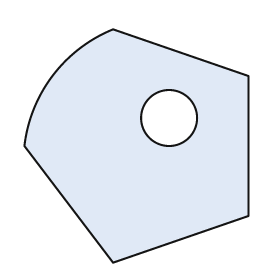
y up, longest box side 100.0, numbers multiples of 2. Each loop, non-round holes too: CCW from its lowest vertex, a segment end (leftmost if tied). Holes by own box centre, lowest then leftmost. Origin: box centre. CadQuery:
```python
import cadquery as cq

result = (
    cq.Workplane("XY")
    .moveTo(-10.0, -50.0)
    .lineTo(48.0, -30.0)
    .lineTo(48.0, 30.0)
    .lineTo(-10.0, 50.0)
    .threePointArc((-36.0, 30.0), (-48.0, 0.0))
    .close()
    .moveTo(14.0, 12.0)
    .circle(12.0)
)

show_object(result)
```